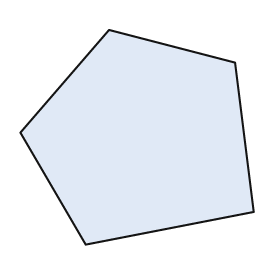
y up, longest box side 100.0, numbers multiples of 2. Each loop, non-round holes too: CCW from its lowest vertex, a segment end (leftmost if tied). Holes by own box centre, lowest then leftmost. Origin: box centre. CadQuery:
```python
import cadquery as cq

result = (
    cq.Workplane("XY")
    .moveTo(-22.0, -46.0)
    .lineTo(50.0, -32.0)
    .lineTo(42.0, 32.0)
    .lineTo(-12.0, 46.0)
    .lineTo(-50.0, 2.0)
    .close()
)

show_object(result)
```